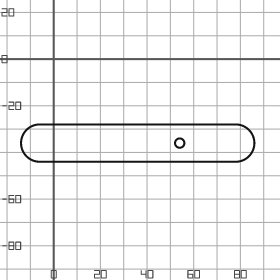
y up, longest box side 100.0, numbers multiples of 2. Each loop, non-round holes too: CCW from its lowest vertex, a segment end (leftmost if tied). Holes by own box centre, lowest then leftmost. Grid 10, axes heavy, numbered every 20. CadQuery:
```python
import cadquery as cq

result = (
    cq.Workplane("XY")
    .moveTo(-6.0, -44.0)
    .lineTo(78.0, -44.0)
    .threePointArc((86.0, -36.0), (78.0, -28.0))
    .lineTo(-6.0, -28.0)
    .threePointArc((-14.0, -36.0), (-6.0, -44.0))
    .close()
    .moveTo(54.0, -36.0)
    .circle(2.0)
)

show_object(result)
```